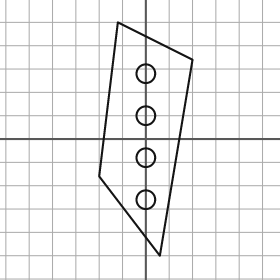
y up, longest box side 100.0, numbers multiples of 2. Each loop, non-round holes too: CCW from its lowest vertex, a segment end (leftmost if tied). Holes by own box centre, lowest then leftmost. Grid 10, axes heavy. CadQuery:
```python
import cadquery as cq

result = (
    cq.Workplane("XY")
    .moveTo(6.0, -50.0)
    .lineTo(20.0, 34.0)
    .lineTo(-12.0, 50.0)
    .lineTo(-20.0, -16.0)
    .close()
    .moveTo(0.0, -26.0)
    .circle(4.0)
    .moveTo(0.0, -8.0)
    .circle(4.0)
    .moveTo(0.0, 10.0)
    .circle(4.0)
    .moveTo(0.0, 28.0)
    .circle(4.0)
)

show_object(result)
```